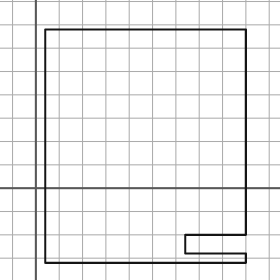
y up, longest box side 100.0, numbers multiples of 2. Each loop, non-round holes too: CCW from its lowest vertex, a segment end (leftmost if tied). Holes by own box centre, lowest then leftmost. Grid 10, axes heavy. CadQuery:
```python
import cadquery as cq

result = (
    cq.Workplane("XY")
    .moveTo(4.0, -32.0)
    .lineTo(90.0, -32.0)
    .lineTo(90.0, -28.0)
    .lineTo(64.0, -28.0)
    .lineTo(64.0, -20.0)
    .lineTo(90.0, -20.0)
    .lineTo(90.0, 68.0)
    .lineTo(4.0, 68.0)
    .close()
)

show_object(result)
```